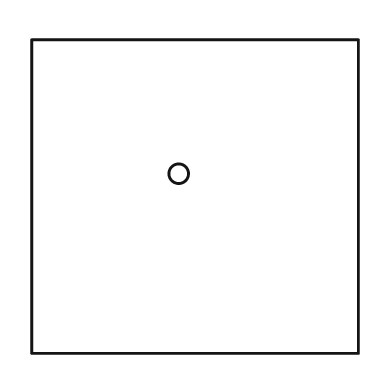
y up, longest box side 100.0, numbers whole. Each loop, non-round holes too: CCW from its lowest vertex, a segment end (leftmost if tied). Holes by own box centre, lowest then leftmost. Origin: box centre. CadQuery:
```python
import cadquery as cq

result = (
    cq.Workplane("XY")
    .moveTo(-50.0, -48.0)
    .lineTo(50.0, -48.0)
    .lineTo(50.0, 48.0)
    .lineTo(-50.0, 48.0)
    .close()
    .moveTo(-5.0, 7.0)
    .circle(3.0)
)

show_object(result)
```